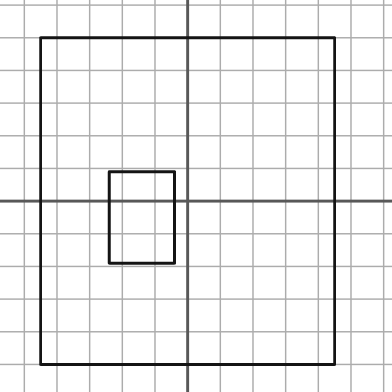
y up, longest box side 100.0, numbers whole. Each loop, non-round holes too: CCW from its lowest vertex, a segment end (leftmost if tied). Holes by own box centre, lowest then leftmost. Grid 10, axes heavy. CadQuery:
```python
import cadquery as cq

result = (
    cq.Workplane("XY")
    .moveTo(-45.0, -50.0)
    .lineTo(45.0, -50.0)
    .lineTo(45.0, 50.0)
    .lineTo(-45.0, 50.0)
    .close()
    .moveTo(-24.0, -19.0)
    .lineTo(-4.0, -19.0)
    .lineTo(-4.0, 9.0)
    .lineTo(-24.0, 9.0)
    .close()
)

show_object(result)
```